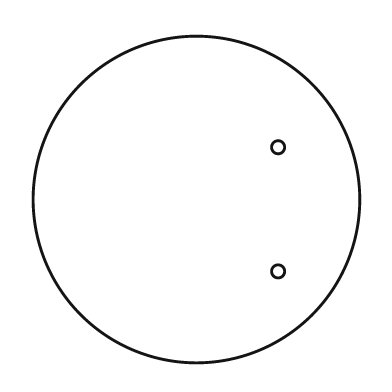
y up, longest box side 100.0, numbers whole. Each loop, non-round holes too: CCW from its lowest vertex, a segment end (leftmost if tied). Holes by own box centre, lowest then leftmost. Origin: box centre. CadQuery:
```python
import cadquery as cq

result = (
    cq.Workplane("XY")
    .moveTo(0.0, 0.0)
    .circle(50.0)
    .moveTo(25.0, -22.0)
    .circle(2.0)
    .moveTo(25.0, 16.0)
    .circle(2.0)
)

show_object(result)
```